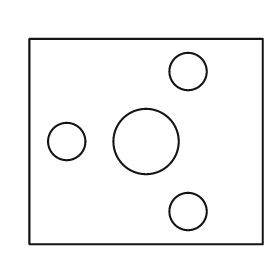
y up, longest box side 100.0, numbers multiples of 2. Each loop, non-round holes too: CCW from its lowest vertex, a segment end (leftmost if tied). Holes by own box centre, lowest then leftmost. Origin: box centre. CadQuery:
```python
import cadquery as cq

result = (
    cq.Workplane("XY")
    .moveTo(-50.0, -44.0)
    .lineTo(50.0, -44.0)
    .lineTo(50.0, 44.0)
    .lineTo(-50.0, 44.0)
    .close()
    .moveTo(18.0, -30.0)
    .circle(8.0)
    .moveTo(-34.0, 0.0)
    .circle(8.0)
    .moveTo(0.0, 0.0)
    .circle(14.0)
    .moveTo(18.0, 30.0)
    .circle(8.0)
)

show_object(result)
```